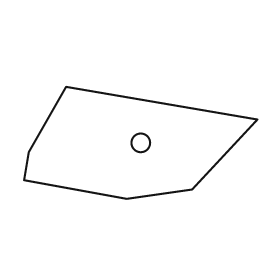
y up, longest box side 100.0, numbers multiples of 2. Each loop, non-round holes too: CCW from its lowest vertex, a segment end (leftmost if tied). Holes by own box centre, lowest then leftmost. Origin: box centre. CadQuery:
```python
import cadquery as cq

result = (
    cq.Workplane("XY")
    .moveTo(-6.0, -24.0)
    .lineTo(22.0, -20.0)
    .lineTo(50.0, 10.0)
    .lineTo(-32.0, 24.0)
    .lineTo(-48.0, -4.0)
    .lineTo(-50.0, -16.0)
    .close()
    .moveTo(0.0, 0.0)
    .circle(4.0)
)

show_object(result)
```